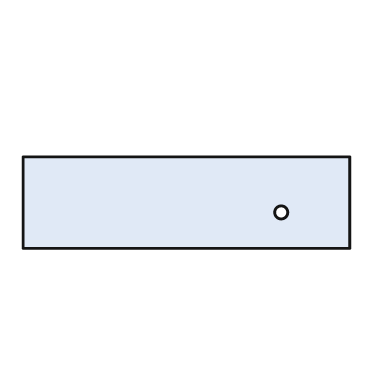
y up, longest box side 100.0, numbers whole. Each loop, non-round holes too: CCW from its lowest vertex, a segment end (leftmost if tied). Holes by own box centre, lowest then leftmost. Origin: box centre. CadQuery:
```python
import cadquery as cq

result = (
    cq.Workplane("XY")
    .moveTo(-50.0, -14.0)
    .lineTo(50.0, -14.0)
    .lineTo(50.0, 14.0)
    .lineTo(-50.0, 14.0)
    .close()
    .moveTo(29.0, -3.0)
    .circle(2.0)
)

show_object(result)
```